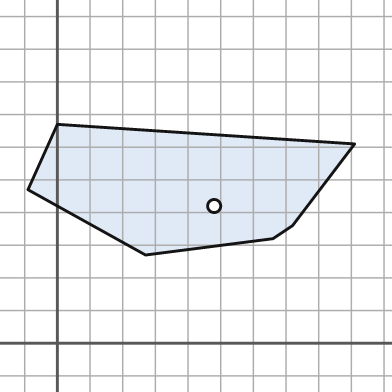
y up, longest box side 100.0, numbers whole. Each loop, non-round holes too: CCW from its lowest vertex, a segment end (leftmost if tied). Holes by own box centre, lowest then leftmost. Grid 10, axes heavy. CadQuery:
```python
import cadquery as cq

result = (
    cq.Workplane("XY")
    .moveTo(27.0, 27.0)
    .lineTo(66.0, 32.0)
    .lineTo(72.0, 36.0)
    .lineTo(91.0, 61.0)
    .lineTo(0.0, 67.0)
    .lineTo(-9.0, 47.0)
    .close()
    .moveTo(48.0, 42.0)
    .circle(2.0)
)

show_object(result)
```